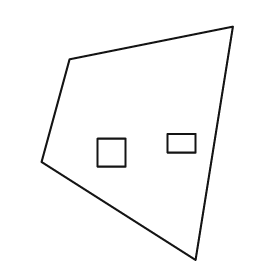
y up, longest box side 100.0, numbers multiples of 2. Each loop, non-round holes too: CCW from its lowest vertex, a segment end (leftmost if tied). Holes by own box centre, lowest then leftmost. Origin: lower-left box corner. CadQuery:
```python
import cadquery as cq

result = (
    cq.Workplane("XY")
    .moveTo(66.0, 0.0)
    .lineTo(82.0, 100.0)
    .lineTo(12.0, 86.0)
    .lineTo(0.0, 42.0)
    .close()
    .moveTo(24.0, 40.0)
    .lineTo(36.0, 40.0)
    .lineTo(36.0, 52.0)
    .lineTo(24.0, 52.0)
    .close()
    .moveTo(54.0, 46.0)
    .lineTo(66.0, 46.0)
    .lineTo(66.0, 54.0)
    .lineTo(54.0, 54.0)
    .close()
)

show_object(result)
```